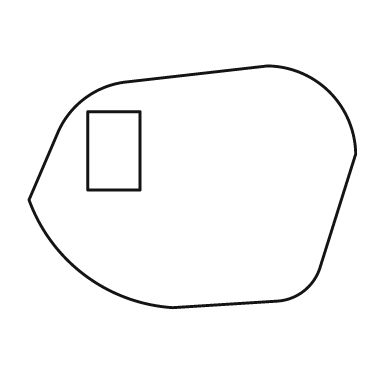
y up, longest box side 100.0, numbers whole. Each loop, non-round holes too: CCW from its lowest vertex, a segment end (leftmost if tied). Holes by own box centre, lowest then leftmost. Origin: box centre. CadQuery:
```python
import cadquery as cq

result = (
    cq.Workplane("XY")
    .moveTo(-6.0, -37.0)
    .lineTo(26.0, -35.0)
    .threePointArc((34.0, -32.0), (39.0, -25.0))
    .lineTo(50.0, 10.0)
    .threePointArc((42.0, 29.0), (23.0, 37.0))
    .lineTo(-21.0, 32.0)
    .threePointArc((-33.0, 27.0), (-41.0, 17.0))
    .lineTo(-50.0, -4.0)
    .threePointArc((-33.0, -27.0), (-6.0, -37.0))
    .close()
    .moveTo(-32.0, -1.0)
    .lineTo(-16.0, -1.0)
    .lineTo(-16.0, 23.0)
    .lineTo(-32.0, 23.0)
    .close()
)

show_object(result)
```